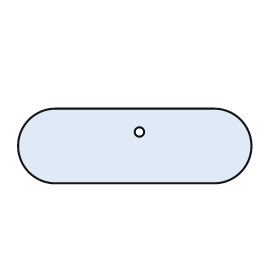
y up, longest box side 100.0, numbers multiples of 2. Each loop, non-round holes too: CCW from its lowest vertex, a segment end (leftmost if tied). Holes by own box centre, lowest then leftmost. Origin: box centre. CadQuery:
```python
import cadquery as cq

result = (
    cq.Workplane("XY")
    .moveTo(-34.0, -16.0)
    .lineTo(34.0, -16.0)
    .threePointArc((50.0, 0.0), (34.0, 16.0))
    .lineTo(-34.0, 16.0)
    .threePointArc((-50.0, 0.0), (-34.0, -16.0))
    .close()
    .moveTo(2.0, 6.0)
    .circle(2.0)
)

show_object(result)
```